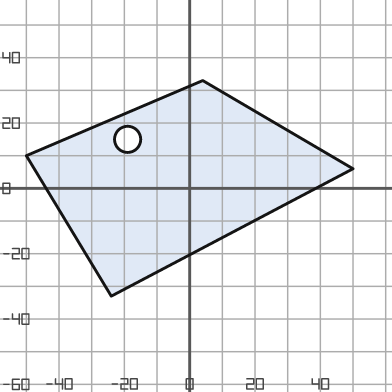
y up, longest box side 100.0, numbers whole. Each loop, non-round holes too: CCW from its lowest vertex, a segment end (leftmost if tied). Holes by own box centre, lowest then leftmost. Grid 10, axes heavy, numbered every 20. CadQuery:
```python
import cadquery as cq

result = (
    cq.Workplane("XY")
    .moveTo(-24.0, -33.0)
    .lineTo(50.0, 6.0)
    .lineTo(4.0, 33.0)
    .lineTo(-50.0, 10.0)
    .close()
    .moveTo(-19.0, 15.0)
    .circle(4.0)
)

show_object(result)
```